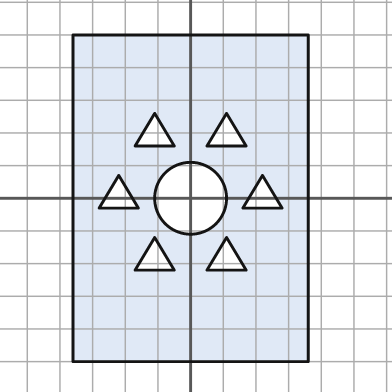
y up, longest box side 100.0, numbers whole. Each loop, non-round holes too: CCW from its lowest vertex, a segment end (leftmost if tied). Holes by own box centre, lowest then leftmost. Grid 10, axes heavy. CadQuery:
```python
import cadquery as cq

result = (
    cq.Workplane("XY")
    .moveTo(-36.0, -50.0)
    .lineTo(36.0, -50.0)
    .lineTo(36.0, 50.0)
    .lineTo(-36.0, 50.0)
    .close()
    .moveTo(-17.0, -22.0)
    .lineTo(-5.0, -22.0)
    .lineTo(-11.0, -12.0)
    .close()
    .moveTo(5.0, -22.0)
    .lineTo(17.0, -22.0)
    .lineTo(11.0, -12.0)
    .close()
    .moveTo(0.0, 0.0)
    .circle(11.0)
    .moveTo(-28.0, -3.0)
    .lineTo(-16.0, -3.0)
    .lineTo(-22.0, 7.0)
    .close()
    .moveTo(16.0, -3.0)
    .lineTo(28.0, -3.0)
    .lineTo(22.0, 7.0)
    .close()
    .moveTo(-17.0, 16.0)
    .lineTo(-5.0, 16.0)
    .lineTo(-11.0, 26.0)
    .close()
    .moveTo(5.0, 16.0)
    .lineTo(17.0, 16.0)
    .lineTo(11.0, 26.0)
    .close()
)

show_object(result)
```